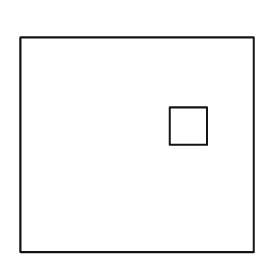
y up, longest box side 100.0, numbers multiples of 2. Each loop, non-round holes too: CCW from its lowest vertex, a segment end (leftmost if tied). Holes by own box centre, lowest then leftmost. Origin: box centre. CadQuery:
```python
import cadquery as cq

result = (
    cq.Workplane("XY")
    .moveTo(-50.0, -46.0)
    .lineTo(50.0, -46.0)
    .lineTo(50.0, 46.0)
    .lineTo(-50.0, 46.0)
    .close()
    .moveTo(14.0, 0.0)
    .lineTo(30.0, 0.0)
    .lineTo(30.0, 16.0)
    .lineTo(14.0, 16.0)
    .close()
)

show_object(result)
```